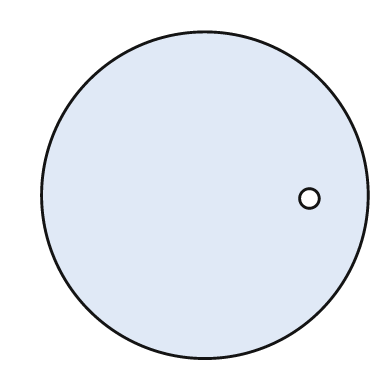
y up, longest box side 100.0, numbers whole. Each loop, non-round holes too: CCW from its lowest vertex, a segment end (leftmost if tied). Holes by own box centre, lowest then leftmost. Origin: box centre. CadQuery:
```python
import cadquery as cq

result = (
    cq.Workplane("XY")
    .moveTo(0.0, 0.0)
    .circle(50.0)
    .moveTo(32.0, -1.0)
    .circle(3.0)
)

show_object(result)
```